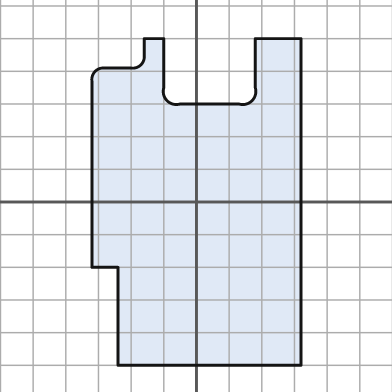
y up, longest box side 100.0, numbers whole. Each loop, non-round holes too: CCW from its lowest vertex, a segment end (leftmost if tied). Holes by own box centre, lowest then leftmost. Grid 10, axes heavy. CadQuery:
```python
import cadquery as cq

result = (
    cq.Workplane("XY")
    .moveTo(-24.0, -50.0)
    .lineTo(32.0, -50.0)
    .lineTo(32.0, 50.0)
    .lineTo(18.0, 50.0)
    .lineTo(18.0, 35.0)
    .threePointArc((17.0, 31.0), (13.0, 30.0))
    .lineTo(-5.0, 30.0)
    .threePointArc((-9.0, 31.0), (-10.0, 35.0))
    .lineTo(-10.0, 50.0)
    .lineTo(-16.0, 50.0)
    .lineTo(-16.0, 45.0)
    .threePointArc((-17.0, 42.0), (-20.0, 41.0))
    .lineTo(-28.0, 41.0)
    .threePointArc((-31.0, 40.0), (-32.0, 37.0))
    .lineTo(-32.0, -20.0)
    .lineTo(-24.0, -20.0)
    .close()
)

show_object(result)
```